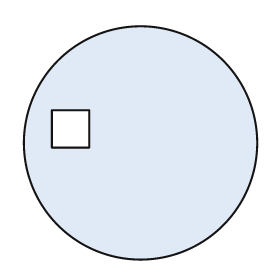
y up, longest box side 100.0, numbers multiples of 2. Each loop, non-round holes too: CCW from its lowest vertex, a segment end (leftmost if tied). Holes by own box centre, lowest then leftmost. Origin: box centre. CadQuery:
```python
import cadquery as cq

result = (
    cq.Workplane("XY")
    .moveTo(0.0, 0.0)
    .circle(50.0)
    .moveTo(-38.0, -2.0)
    .lineTo(-22.0, -2.0)
    .lineTo(-22.0, 14.0)
    .lineTo(-38.0, 14.0)
    .close()
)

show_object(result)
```